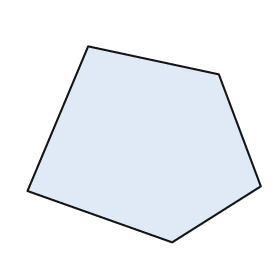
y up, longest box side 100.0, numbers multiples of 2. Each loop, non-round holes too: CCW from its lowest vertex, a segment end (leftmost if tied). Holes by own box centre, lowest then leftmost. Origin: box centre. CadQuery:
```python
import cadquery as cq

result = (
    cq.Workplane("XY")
    .moveTo(12.0, -42.0)
    .lineTo(50.0, -18.0)
    .lineTo(32.0, 30.0)
    .lineTo(-24.0, 42.0)
    .lineTo(-50.0, -20.0)
    .close()
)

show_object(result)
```